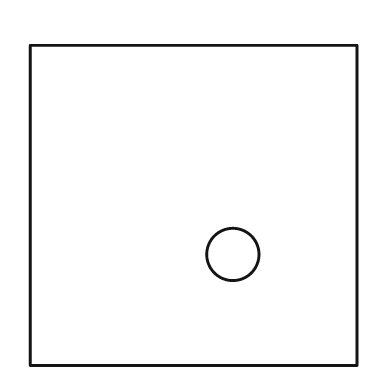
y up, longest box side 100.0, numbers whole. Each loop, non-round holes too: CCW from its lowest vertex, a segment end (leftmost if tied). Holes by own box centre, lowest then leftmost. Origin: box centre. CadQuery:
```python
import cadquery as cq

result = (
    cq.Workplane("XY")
    .moveTo(-50.0, -49.0)
    .lineTo(50.0, -49.0)
    .lineTo(50.0, 49.0)
    .lineTo(-50.0, 49.0)
    .close()
    .moveTo(12.0, -15.0)
    .circle(8.0)
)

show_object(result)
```